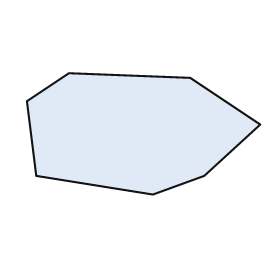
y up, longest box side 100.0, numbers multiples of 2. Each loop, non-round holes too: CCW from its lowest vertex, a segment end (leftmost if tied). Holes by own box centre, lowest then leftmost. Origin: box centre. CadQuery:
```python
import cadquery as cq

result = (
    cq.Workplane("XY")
    .moveTo(4.0, -26.0)
    .lineTo(26.0, -18.0)
    .lineTo(50.0, 4.0)
    .lineTo(20.0, 24.0)
    .lineTo(-32.0, 26.0)
    .lineTo(-50.0, 14.0)
    .lineTo(-46.0, -18.0)
    .close()
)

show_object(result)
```